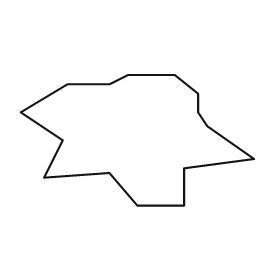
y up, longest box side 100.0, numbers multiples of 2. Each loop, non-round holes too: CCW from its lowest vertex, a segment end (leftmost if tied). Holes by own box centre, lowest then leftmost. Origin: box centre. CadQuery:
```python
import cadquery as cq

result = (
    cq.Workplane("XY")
    .moveTo(0.0, -28.0)
    .lineTo(20.0, -28.0)
    .lineTo(20.0, -12.0)
    .lineTo(50.0, -8.0)
    .lineTo(30.0, 6.0)
    .lineTo(26.0, 12.0)
    .lineTo(26.0, 20.0)
    .lineTo(16.0, 28.0)
    .lineTo(-4.0, 28.0)
    .lineTo(-12.0, 24.0)
    .lineTo(-30.0, 24.0)
    .lineTo(-50.0, 12.0)
    .lineTo(-32.0, 0.0)
    .lineTo(-40.0, -16.0)
    .lineTo(-12.0, -14.0)
    .close()
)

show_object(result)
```